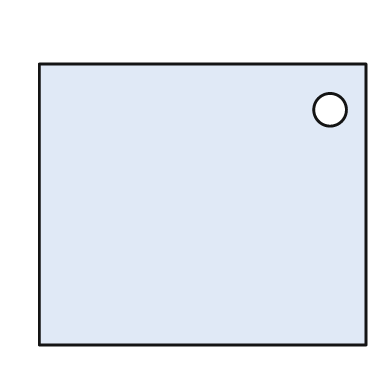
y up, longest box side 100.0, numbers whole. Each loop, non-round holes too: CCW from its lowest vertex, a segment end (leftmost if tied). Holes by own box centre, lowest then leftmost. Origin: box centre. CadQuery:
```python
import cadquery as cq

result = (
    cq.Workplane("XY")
    .moveTo(-50.0, -43.0)
    .lineTo(50.0, -43.0)
    .lineTo(50.0, 43.0)
    .lineTo(-50.0, 43.0)
    .close()
    .moveTo(39.0, 29.0)
    .circle(5.0)
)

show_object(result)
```